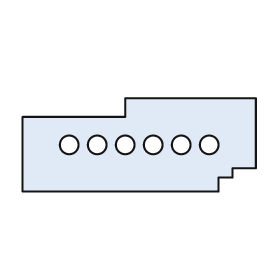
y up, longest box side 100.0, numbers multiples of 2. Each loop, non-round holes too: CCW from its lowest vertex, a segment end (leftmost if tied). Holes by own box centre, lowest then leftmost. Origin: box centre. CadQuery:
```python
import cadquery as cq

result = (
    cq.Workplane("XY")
    .moveTo(-50.0, -20.0)
    .lineTo(34.0, -20.0)
    .lineTo(34.0, -14.0)
    .lineTo(40.0, -14.0)
    .lineTo(40.0, -10.0)
    .lineTo(50.0, -10.0)
    .lineTo(50.0, 20.0)
    .lineTo(-6.0, 20.0)
    .lineTo(-6.0, 12.0)
    .lineTo(-50.0, 12.0)
    .close()
    .moveTo(-30.0, 0.0)
    .circle(4.0)
    .moveTo(-18.0, 0.0)
    .circle(4.0)
    .moveTo(-6.0, 0.0)
    .circle(4.0)
    .moveTo(6.0, 0.0)
    .circle(4.0)
    .moveTo(18.0, 0.0)
    .circle(4.0)
    .moveTo(30.0, 0.0)
    .circle(4.0)
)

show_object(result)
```